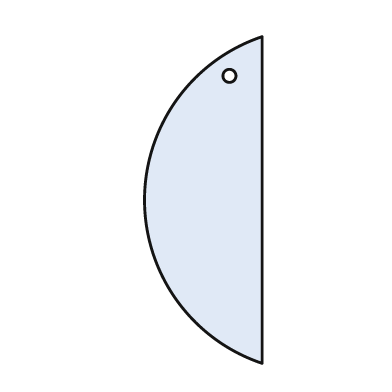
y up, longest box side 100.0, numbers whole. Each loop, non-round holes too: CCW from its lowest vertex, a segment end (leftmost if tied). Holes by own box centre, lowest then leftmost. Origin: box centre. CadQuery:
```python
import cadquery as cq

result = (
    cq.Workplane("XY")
    .moveTo(18.0, -50.0)
    .lineTo(18.0, 50.0)
    .threePointArc((-18.0, 0.0), (18.0, -50.0))
    .close()
    .moveTo(8.0, 38.0)
    .circle(2.0)
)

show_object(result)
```